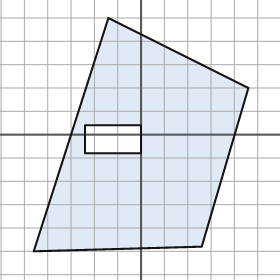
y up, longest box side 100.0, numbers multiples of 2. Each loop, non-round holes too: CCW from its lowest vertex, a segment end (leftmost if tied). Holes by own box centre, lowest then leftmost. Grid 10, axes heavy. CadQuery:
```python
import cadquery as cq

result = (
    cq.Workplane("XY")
    .moveTo(-46.0, -50.0)
    .lineTo(26.0, -48.0)
    .lineTo(46.0, 20.0)
    .lineTo(-14.0, 50.0)
    .close()
    .moveTo(-24.0, -8.0)
    .lineTo(0.0, -8.0)
    .lineTo(0.0, 4.0)
    .lineTo(-24.0, 4.0)
    .close()
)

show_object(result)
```